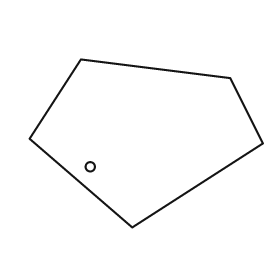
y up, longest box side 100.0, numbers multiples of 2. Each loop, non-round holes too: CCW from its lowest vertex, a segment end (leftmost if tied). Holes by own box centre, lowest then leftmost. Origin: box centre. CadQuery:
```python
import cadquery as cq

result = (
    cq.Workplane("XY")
    .moveTo(-6.0, -36.0)
    .lineTo(50.0, 0.0)
    .lineTo(36.0, 28.0)
    .lineTo(-28.0, 36.0)
    .lineTo(-50.0, 2.0)
    .close()
    .moveTo(-24.0, -10.0)
    .circle(2.0)
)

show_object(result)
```